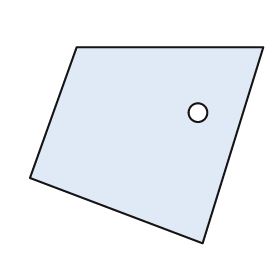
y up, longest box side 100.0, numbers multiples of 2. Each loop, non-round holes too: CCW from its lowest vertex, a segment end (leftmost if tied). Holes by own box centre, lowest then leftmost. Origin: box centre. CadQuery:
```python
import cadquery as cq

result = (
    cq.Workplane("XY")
    .moveTo(24.0, -42.0)
    .lineTo(50.0, 42.0)
    .lineTo(-30.0, 42.0)
    .lineTo(-50.0, -14.0)
    .close()
    .moveTo(22.0, 14.0)
    .circle(4.0)
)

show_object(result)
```